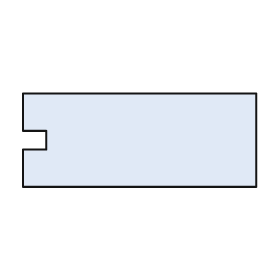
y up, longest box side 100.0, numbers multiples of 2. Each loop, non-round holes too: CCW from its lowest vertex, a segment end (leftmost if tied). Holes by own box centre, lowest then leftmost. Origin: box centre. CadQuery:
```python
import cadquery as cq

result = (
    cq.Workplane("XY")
    .moveTo(-50.0, -20.0)
    .lineTo(50.0, -20.0)
    .lineTo(50.0, 20.0)
    .lineTo(-50.0, 20.0)
    .lineTo(-50.0, 4.0)
    .lineTo(-40.0, 4.0)
    .lineTo(-40.0, -4.0)
    .lineTo(-50.0, -4.0)
    .close()
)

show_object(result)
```